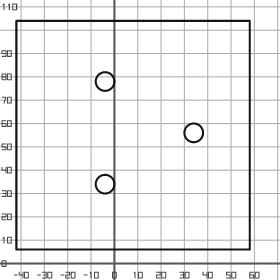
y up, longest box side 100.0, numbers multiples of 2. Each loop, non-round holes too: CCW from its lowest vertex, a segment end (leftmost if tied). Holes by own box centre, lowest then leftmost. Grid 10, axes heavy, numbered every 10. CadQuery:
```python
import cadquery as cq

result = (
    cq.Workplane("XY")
    .moveTo(-42.0, 6.0)
    .lineTo(58.0, 6.0)
    .lineTo(58.0, 104.0)
    .lineTo(-42.0, 104.0)
    .close()
    .moveTo(-4.0, 34.0)
    .circle(4.0)
    .moveTo(34.0, 56.0)
    .circle(4.0)
    .moveTo(-4.0, 78.0)
    .circle(4.0)
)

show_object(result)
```